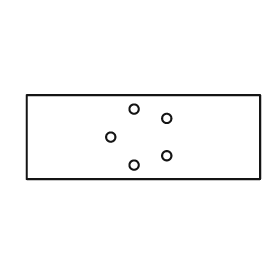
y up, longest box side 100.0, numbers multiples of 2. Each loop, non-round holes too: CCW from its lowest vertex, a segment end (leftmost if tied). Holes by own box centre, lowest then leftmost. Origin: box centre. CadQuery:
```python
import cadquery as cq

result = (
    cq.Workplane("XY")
    .moveTo(-50.0, -18.0)
    .lineTo(50.0, -18.0)
    .lineTo(50.0, 18.0)
    .lineTo(-50.0, 18.0)
    .close()
    .moveTo(-4.0, -12.0)
    .circle(2.0)
    .moveTo(10.0, -8.0)
    .circle(2.0)
    .moveTo(-14.0, 0.0)
    .circle(2.0)
    .moveTo(10.0, 8.0)
    .circle(2.0)
    .moveTo(-4.0, 12.0)
    .circle(2.0)
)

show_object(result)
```